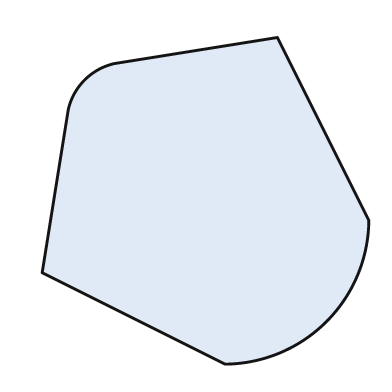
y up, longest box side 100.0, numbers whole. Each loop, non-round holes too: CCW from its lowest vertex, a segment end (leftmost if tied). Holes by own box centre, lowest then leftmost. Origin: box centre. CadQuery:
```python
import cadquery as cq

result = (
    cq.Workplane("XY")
    .moveTo(6.0, -50.0)
    .threePointArc((37.0, -37.0), (50.0, -6.0))
    .lineTo(22.0, 50.0)
    .lineTo(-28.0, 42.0)
    .threePointArc((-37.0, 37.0), (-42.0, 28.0))
    .lineTo(-50.0, -22.0)
    .close()
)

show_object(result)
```